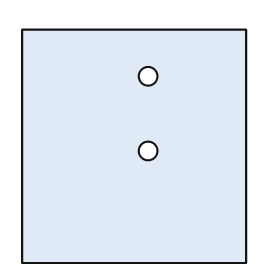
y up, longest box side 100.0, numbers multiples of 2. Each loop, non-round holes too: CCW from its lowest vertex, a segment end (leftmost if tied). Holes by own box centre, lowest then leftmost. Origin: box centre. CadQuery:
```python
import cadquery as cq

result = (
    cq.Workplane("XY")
    .moveTo(-48.0, -50.0)
    .lineTo(48.0, -50.0)
    .lineTo(48.0, 50.0)
    .lineTo(-48.0, 50.0)
    .close()
    .moveTo(6.0, -2.0)
    .circle(4.0)
    .moveTo(6.0, 30.0)
    .circle(4.0)
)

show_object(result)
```